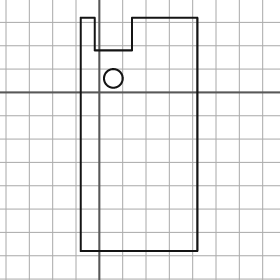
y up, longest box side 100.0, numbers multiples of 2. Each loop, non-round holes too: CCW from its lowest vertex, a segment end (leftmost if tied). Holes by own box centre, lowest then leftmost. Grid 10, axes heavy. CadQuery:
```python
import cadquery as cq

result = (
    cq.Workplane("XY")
    .moveTo(-8.0, -68.0)
    .lineTo(42.0, -68.0)
    .lineTo(42.0, 32.0)
    .lineTo(14.0, 32.0)
    .lineTo(14.0, 18.0)
    .lineTo(-2.0, 18.0)
    .lineTo(-2.0, 32.0)
    .lineTo(-8.0, 32.0)
    .close()
    .moveTo(6.0, 6.0)
    .circle(4.0)
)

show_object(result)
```